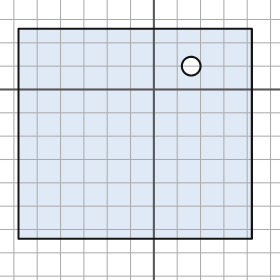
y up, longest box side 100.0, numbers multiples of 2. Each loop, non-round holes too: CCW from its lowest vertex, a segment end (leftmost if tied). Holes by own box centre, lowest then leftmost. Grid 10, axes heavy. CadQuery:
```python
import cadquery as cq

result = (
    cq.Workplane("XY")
    .moveTo(-58.0, -64.0)
    .lineTo(42.0, -64.0)
    .lineTo(42.0, 26.0)
    .lineTo(-58.0, 26.0)
    .close()
    .moveTo(16.0, 10.0)
    .circle(4.0)
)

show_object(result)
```